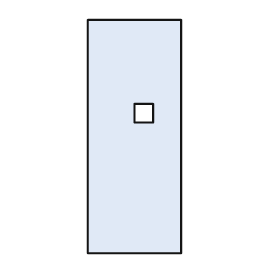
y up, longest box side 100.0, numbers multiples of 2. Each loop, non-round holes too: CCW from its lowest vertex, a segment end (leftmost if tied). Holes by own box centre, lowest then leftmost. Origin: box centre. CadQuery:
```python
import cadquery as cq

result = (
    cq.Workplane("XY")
    .moveTo(-20.0, -50.0)
    .lineTo(20.0, -50.0)
    .lineTo(20.0, 50.0)
    .lineTo(-20.0, 50.0)
    .close()
    .moveTo(0.0, 6.0)
    .lineTo(8.0, 6.0)
    .lineTo(8.0, 14.0)
    .lineTo(0.0, 14.0)
    .close()
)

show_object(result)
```